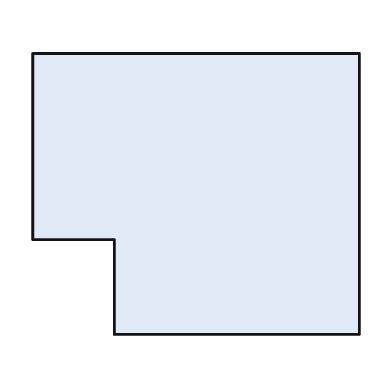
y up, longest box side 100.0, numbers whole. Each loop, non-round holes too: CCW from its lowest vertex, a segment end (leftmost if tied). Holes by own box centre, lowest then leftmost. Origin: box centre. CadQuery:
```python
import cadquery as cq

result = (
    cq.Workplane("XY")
    .moveTo(-25.0, -43.0)
    .lineTo(50.0, -43.0)
    .lineTo(50.0, 43.0)
    .lineTo(-50.0, 43.0)
    .lineTo(-50.0, -14.0)
    .lineTo(-25.0, -14.0)
    .close()
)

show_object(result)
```